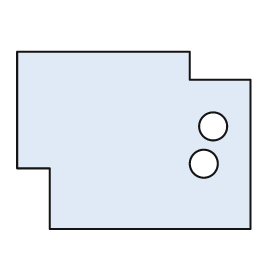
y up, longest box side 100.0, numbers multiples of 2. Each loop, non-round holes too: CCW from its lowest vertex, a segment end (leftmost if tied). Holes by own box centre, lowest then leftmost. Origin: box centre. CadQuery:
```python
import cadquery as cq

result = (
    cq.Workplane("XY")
    .moveTo(-36.0, -38.0)
    .lineTo(50.0, -38.0)
    .lineTo(50.0, 26.0)
    .lineTo(24.0, 26.0)
    .lineTo(24.0, 38.0)
    .lineTo(-50.0, 38.0)
    .lineTo(-50.0, -12.0)
    .lineTo(-36.0, -12.0)
    .close()
    .moveTo(30.0, -10.0)
    .circle(6.0)
    .moveTo(34.0, 6.0)
    .circle(6.0)
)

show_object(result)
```